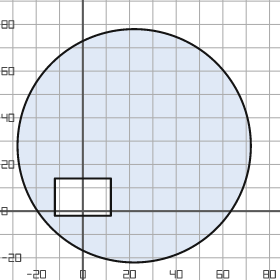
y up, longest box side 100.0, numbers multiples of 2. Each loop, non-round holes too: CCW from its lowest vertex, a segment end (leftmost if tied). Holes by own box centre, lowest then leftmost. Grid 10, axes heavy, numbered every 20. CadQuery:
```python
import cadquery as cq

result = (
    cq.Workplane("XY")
    .moveTo(22.0, 28.0)
    .circle(50.0)
    .moveTo(-12.0, -2.0)
    .lineTo(12.0, -2.0)
    .lineTo(12.0, 14.0)
    .lineTo(-12.0, 14.0)
    .close()
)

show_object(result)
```